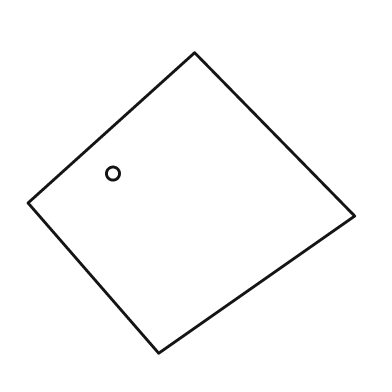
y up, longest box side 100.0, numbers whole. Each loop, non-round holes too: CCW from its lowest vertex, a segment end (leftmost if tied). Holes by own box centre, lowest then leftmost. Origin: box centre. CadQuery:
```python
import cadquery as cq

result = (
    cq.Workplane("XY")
    .moveTo(-10.0, -46.0)
    .lineTo(50.0, -4.0)
    .lineTo(1.0, 46.0)
    .lineTo(-50.0, 0.0)
    .close()
    .moveTo(-24.0, 9.0)
    .circle(2.0)
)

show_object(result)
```